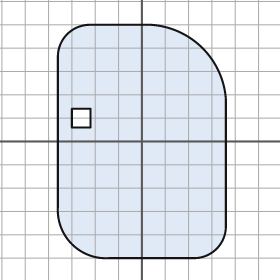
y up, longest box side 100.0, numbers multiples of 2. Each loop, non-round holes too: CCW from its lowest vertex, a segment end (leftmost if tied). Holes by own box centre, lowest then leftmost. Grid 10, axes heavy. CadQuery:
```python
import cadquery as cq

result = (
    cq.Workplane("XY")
    .moveTo(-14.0, -50.0)
    .lineTo(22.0, -50.0)
    .threePointArc((32.0, -46.0), (36.0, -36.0))
    .lineTo(36.0, 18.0)
    .threePointArc((26.0, 40.0), (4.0, 50.0))
    .lineTo(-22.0, 50.0)
    .threePointArc((-32.0, 46.0), (-36.0, 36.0))
    .lineTo(-36.0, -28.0)
    .threePointArc((-30.0, -44.0), (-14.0, -50.0))
    .close()
    .moveTo(-30.0, 6.0)
    .lineTo(-22.0, 6.0)
    .lineTo(-22.0, 14.0)
    .lineTo(-30.0, 14.0)
    .close()
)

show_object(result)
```